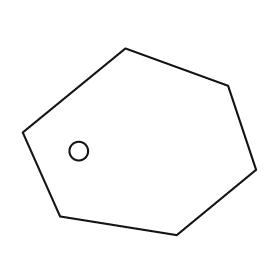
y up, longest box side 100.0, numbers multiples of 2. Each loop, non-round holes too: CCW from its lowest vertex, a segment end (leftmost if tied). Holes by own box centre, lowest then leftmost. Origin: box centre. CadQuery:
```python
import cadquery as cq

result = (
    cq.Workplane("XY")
    .moveTo(16.0, -40.0)
    .lineTo(50.0, -12.0)
    .lineTo(38.0, 24.0)
    .lineTo(-6.0, 40.0)
    .lineTo(-50.0, 4.0)
    .lineTo(-34.0, -32.0)
    .close()
    .moveTo(-26.0, -4.0)
    .circle(4.0)
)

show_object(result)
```